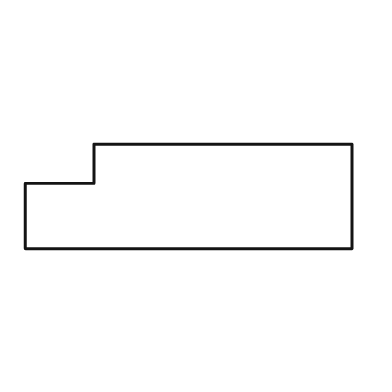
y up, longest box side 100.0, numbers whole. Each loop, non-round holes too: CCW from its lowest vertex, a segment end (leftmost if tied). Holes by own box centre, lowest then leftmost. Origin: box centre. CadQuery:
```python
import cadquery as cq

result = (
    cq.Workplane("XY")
    .moveTo(-50.0, -16.0)
    .lineTo(50.0, -16.0)
    .lineTo(50.0, 16.0)
    .lineTo(-29.0, 16.0)
    .lineTo(-29.0, 4.0)
    .lineTo(-50.0, 4.0)
    .close()
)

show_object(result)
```